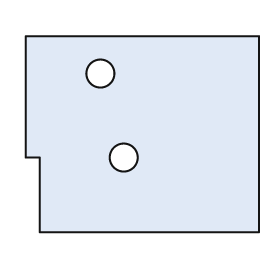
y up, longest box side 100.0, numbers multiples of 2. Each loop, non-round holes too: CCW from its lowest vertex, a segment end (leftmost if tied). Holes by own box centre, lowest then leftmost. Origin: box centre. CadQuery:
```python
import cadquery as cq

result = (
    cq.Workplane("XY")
    .moveTo(-44.0, -42.0)
    .lineTo(50.0, -42.0)
    .lineTo(50.0, 42.0)
    .lineTo(-50.0, 42.0)
    .lineTo(-50.0, -10.0)
    .lineTo(-44.0, -10.0)
    .close()
    .moveTo(-8.0, -10.0)
    .circle(6.0)
    .moveTo(-18.0, 26.0)
    .circle(6.0)
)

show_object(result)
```